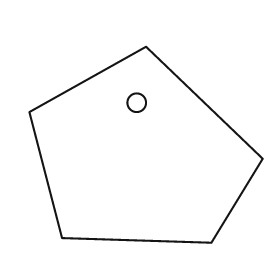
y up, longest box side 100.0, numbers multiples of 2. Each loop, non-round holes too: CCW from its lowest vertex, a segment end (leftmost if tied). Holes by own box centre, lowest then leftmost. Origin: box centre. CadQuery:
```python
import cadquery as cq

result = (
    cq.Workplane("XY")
    .moveTo(28.0, -42.0)
    .lineTo(50.0, -6.0)
    .lineTo(0.0, 42.0)
    .lineTo(-50.0, 14.0)
    .lineTo(-36.0, -40.0)
    .close()
    .moveTo(-4.0, 18.0)
    .circle(4.0)
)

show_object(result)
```